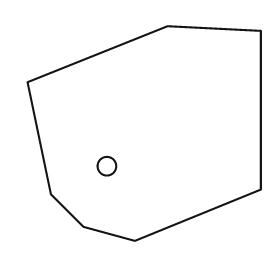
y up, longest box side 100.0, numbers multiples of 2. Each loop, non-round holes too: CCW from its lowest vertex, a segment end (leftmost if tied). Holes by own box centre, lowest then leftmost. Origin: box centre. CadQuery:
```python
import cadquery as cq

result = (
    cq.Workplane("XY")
    .moveTo(-4.0, -46.0)
    .lineTo(50.0, -24.0)
    .lineTo(50.0, 44.0)
    .lineTo(10.0, 46.0)
    .lineTo(-50.0, 22.0)
    .lineTo(-40.0, -26.0)
    .lineTo(-26.0, -40.0)
    .close()
    .moveTo(-16.0, -14.0)
    .circle(4.0)
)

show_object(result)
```